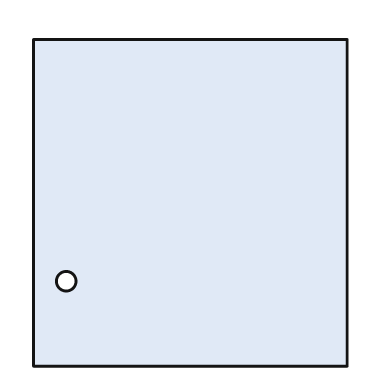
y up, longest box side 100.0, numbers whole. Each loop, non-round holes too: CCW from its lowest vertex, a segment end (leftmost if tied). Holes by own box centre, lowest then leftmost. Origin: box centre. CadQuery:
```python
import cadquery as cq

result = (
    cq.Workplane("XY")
    .moveTo(-48.0, -50.0)
    .lineTo(48.0, -50.0)
    .lineTo(48.0, 50.0)
    .lineTo(-48.0, 50.0)
    .close()
    .moveTo(-38.0, -24.0)
    .circle(3.0)
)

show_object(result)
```